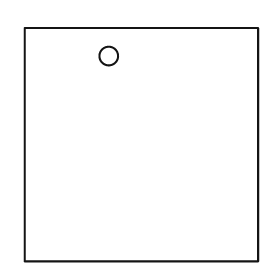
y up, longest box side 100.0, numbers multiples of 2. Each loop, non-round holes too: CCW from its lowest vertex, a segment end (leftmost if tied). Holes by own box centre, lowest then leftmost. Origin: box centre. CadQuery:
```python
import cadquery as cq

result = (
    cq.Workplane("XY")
    .moveTo(-50.0, -50.0)
    .lineTo(50.0, -50.0)
    .lineTo(50.0, 50.0)
    .lineTo(-50.0, 50.0)
    .close()
    .moveTo(-14.0, 38.0)
    .circle(4.0)
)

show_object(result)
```